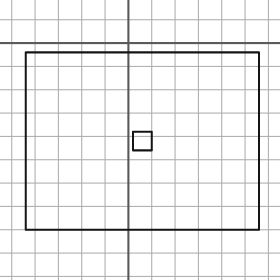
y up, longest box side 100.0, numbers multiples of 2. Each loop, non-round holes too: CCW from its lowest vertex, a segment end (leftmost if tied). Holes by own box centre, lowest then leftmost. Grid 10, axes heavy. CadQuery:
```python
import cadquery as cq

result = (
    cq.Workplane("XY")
    .moveTo(-44.0, -80.0)
    .lineTo(56.0, -80.0)
    .lineTo(56.0, -4.0)
    .lineTo(-44.0, -4.0)
    .close()
    .moveTo(2.0, -46.0)
    .lineTo(10.0, -46.0)
    .lineTo(10.0, -38.0)
    .lineTo(2.0, -38.0)
    .close()
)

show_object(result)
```